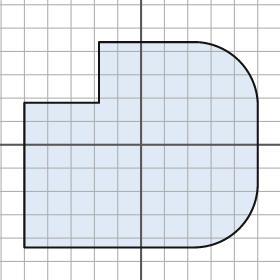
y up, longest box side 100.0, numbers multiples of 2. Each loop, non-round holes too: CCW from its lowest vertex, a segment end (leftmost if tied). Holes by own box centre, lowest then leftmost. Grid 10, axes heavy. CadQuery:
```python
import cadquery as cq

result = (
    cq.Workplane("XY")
    .moveTo(-50.0, -44.0)
    .lineTo(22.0, -44.0)
    .threePointArc((42.0, -36.0), (50.0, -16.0))
    .lineTo(50.0, 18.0)
    .threePointArc((42.0, 36.0), (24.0, 44.0))
    .lineTo(-18.0, 44.0)
    .lineTo(-18.0, 18.0)
    .lineTo(-50.0, 18.0)
    .close()
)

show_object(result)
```